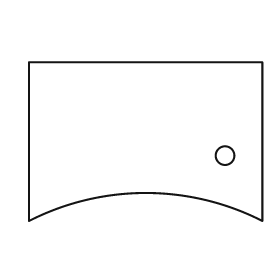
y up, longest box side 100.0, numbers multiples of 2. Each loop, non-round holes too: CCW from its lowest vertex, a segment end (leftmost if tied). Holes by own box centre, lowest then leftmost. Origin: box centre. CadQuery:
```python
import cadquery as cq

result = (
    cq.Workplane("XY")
    .moveTo(-50.0, -34.0)
    .threePointArc((0.0, -22.0), (50.0, -34.0))
    .lineTo(50.0, 34.0)
    .lineTo(-50.0, 34.0)
    .close()
    .moveTo(34.0, -6.0)
    .circle(4.0)
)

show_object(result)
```